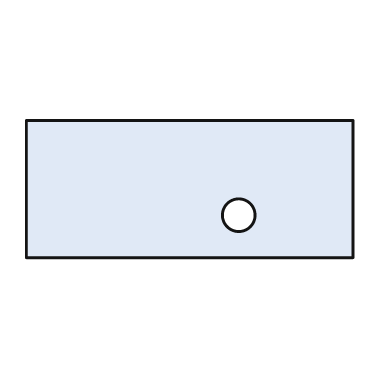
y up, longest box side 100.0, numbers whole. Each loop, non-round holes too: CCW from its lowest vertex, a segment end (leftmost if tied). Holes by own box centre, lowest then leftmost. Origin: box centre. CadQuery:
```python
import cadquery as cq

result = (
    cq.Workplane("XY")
    .moveTo(-50.0, -21.0)
    .lineTo(50.0, -21.0)
    .lineTo(50.0, 21.0)
    .lineTo(-50.0, 21.0)
    .close()
    .moveTo(15.0, -8.0)
    .circle(5.0)
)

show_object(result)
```